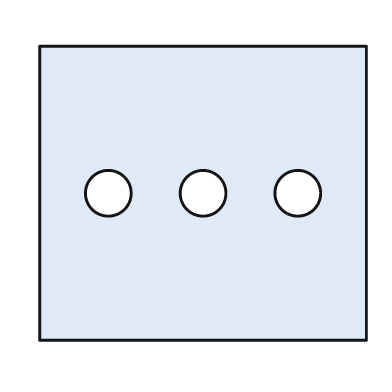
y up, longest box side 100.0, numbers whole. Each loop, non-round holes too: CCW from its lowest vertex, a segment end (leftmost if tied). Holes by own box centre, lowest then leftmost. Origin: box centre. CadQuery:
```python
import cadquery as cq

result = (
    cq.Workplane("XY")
    .moveTo(-50.0, -45.0)
    .lineTo(50.0, -45.0)
    .lineTo(50.0, 45.0)
    .lineTo(-50.0, 45.0)
    .close()
    .moveTo(-29.0, 0.0)
    .circle(7.0)
    .moveTo(0.0, 0.0)
    .circle(7.0)
    .moveTo(29.0, 0.0)
    .circle(7.0)
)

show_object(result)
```